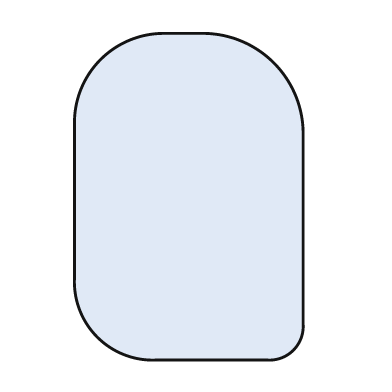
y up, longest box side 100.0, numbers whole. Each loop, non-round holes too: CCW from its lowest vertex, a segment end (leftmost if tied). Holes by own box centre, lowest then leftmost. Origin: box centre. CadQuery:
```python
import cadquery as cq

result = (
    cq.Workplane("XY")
    .moveTo(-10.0, -50.0)
    .lineTo(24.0, -50.0)
    .threePointArc((32.0, -47.0), (35.0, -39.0))
    .lineTo(35.0, 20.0)
    .threePointArc((26.0, 41.0), (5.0, 50.0))
    .lineTo(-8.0, 50.0)
    .threePointArc((-27.0, 42.0), (-35.0, 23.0))
    .lineTo(-35.0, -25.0)
    .threePointArc((-28.0, -43.0), (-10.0, -50.0))
    .close()
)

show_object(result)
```